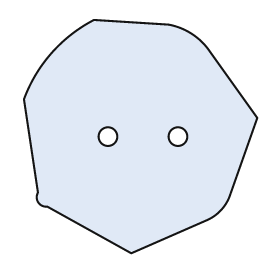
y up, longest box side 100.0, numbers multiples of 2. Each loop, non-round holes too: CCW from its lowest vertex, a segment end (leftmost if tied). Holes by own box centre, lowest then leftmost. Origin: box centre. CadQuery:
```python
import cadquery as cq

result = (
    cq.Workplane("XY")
    .moveTo(-4.0, -50.0)
    .lineTo(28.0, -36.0)
    .threePointArc((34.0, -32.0), (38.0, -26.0))
    .lineTo(50.0, 8.0)
    .lineTo(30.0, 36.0)
    .threePointArc((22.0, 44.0), (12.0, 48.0))
    .lineTo(-20.0, 50.0)
    .threePointArc((-38.0, 36.0), (-50.0, 16.0))
    .lineTo(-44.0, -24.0)
    .threePointArc((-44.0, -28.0), (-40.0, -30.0))
    .close()
    .moveTo(-14.0, 0.0)
    .circle(4.0)
    .moveTo(16.0, 0.0)
    .circle(4.0)
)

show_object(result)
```